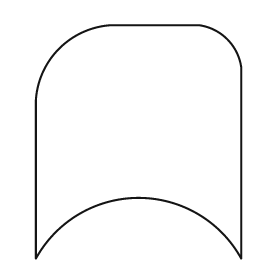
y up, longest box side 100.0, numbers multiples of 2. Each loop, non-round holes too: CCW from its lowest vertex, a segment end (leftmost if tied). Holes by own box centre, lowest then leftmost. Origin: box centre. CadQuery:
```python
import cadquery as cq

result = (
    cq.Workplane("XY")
    .moveTo(-44.0, -50.0)
    .threePointArc((0.0, -24.0), (44.0, -50.0))
    .lineTo(44.0, 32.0)
    .threePointArc((38.0, 44.0), (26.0, 50.0))
    .lineTo(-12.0, 50.0)
    .threePointArc((-34.0, 40.0), (-44.0, 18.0))
    .close()
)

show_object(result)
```